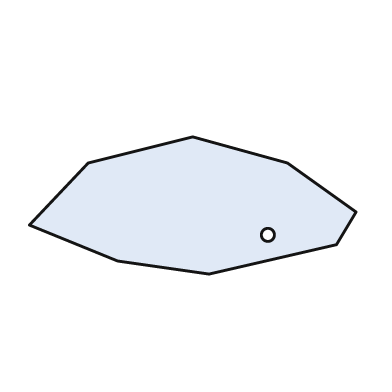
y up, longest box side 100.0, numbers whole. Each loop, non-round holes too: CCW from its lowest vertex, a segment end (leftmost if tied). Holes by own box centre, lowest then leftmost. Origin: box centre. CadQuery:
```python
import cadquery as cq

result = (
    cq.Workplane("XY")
    .moveTo(5.0, -21.0)
    .lineTo(44.0, -12.0)
    .lineTo(50.0, -2.0)
    .lineTo(29.0, 13.0)
    .lineTo(0.0, 21.0)
    .lineTo(-32.0, 13.0)
    .lineTo(-50.0, -6.0)
    .lineTo(-23.0, -17.0)
    .close()
    .moveTo(23.0, -9.0)
    .circle(2.0)
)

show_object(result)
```